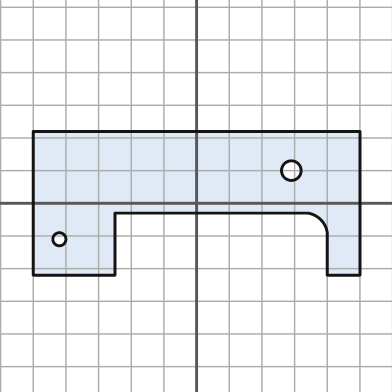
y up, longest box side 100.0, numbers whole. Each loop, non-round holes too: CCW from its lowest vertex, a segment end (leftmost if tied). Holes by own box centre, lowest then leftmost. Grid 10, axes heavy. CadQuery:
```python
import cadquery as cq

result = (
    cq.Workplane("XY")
    .moveTo(-50.0, -22.0)
    .lineTo(-25.0, -22.0)
    .lineTo(-25.0, -3.0)
    .lineTo(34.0, -3.0)
    .threePointArc((38.0, -5.0), (40.0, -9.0))
    .lineTo(40.0, -22.0)
    .lineTo(50.0, -22.0)
    .lineTo(50.0, 22.0)
    .lineTo(-50.0, 22.0)
    .close()
    .moveTo(-42.0, -11.0)
    .circle(2.0)
    .moveTo(29.0, 10.0)
    .circle(3.0)
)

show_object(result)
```